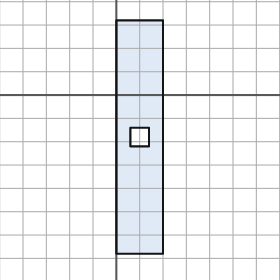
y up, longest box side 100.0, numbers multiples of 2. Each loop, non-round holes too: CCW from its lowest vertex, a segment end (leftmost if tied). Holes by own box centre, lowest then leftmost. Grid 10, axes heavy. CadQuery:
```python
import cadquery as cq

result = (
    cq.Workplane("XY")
    .moveTo(0.0, -68.0)
    .lineTo(20.0, -68.0)
    .lineTo(20.0, 32.0)
    .lineTo(0.0, 32.0)
    .close()
    .moveTo(6.0, -22.0)
    .lineTo(14.0, -22.0)
    .lineTo(14.0, -14.0)
    .lineTo(6.0, -14.0)
    .close()
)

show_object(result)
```